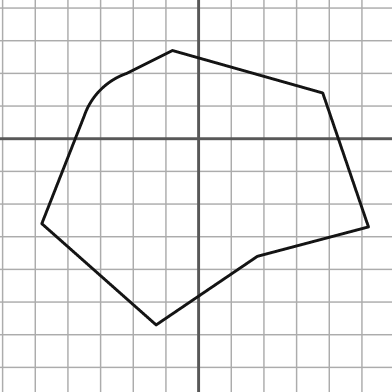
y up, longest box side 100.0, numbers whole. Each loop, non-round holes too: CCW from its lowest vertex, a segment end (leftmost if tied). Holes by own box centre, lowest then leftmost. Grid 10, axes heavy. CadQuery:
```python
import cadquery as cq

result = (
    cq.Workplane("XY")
    .moveTo(-13.0, -57.0)
    .lineTo(18.0, -36.0)
    .lineTo(52.0, -27.0)
    .lineTo(38.0, 14.0)
    .lineTo(-8.0, 27.0)
    .lineTo(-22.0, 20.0)
    .threePointArc((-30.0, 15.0), (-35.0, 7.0))
    .lineTo(-48.0, -26.0)
    .close()
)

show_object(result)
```